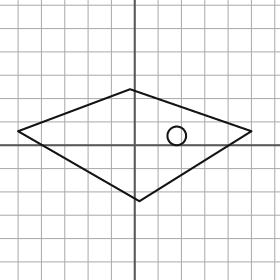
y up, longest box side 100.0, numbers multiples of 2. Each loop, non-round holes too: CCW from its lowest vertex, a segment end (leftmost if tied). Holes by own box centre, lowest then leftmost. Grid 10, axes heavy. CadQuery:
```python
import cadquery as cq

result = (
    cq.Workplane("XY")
    .moveTo(2.0, -24.0)
    .lineTo(50.0, 6.0)
    .lineTo(-2.0, 24.0)
    .lineTo(-50.0, 6.0)
    .close()
    .moveTo(18.0, 4.0)
    .circle(4.0)
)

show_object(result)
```